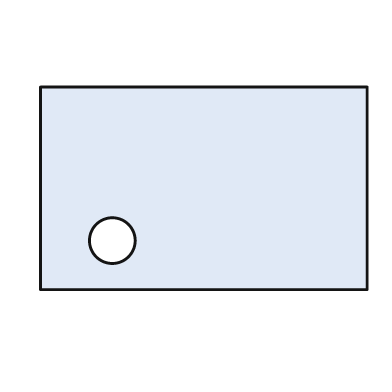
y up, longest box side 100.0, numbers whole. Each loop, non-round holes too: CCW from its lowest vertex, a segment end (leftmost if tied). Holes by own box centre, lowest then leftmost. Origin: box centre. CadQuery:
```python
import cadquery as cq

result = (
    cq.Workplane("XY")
    .moveTo(-50.0, -31.0)
    .lineTo(50.0, -31.0)
    .lineTo(50.0, 31.0)
    .lineTo(-50.0, 31.0)
    .close()
    .moveTo(-28.0, -16.0)
    .circle(7.0)
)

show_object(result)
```